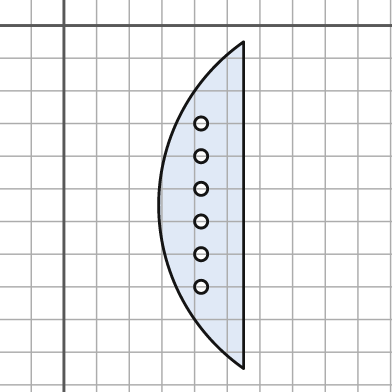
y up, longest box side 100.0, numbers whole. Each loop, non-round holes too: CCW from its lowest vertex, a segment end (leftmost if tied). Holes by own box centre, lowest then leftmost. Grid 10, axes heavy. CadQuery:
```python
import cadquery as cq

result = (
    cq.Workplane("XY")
    .moveTo(55.0, -105.0)
    .lineTo(55.0, -5.0)
    .threePointArc((29.0, -55.0), (55.0, -105.0))
    .close()
    .moveTo(42.0, -80.0)
    .circle(2.0)
    .moveTo(42.0, -70.0)
    .circle(2.0)
    .moveTo(42.0, -60.0)
    .circle(2.0)
    .moveTo(42.0, -50.0)
    .circle(2.0)
    .moveTo(42.0, -40.0)
    .circle(2.0)
    .moveTo(42.0, -30.0)
    .circle(2.0)
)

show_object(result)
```